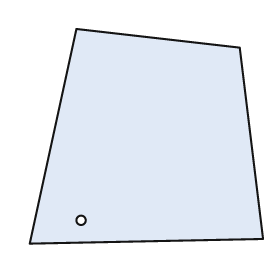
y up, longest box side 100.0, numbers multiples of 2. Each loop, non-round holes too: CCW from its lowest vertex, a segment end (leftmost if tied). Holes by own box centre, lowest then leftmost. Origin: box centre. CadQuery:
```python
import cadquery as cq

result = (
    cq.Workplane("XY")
    .moveTo(-50.0, -46.0)
    .lineTo(50.0, -44.0)
    .lineTo(40.0, 38.0)
    .lineTo(-30.0, 46.0)
    .close()
    .moveTo(-28.0, -36.0)
    .circle(2.0)
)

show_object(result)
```